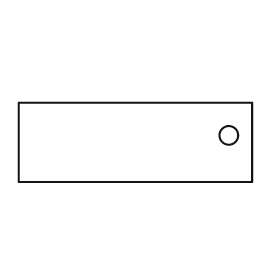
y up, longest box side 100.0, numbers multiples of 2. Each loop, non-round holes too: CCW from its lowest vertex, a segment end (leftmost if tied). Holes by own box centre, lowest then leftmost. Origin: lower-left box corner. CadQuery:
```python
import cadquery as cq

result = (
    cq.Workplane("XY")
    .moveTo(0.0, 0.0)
    .lineTo(100.0, 0.0)
    .lineTo(100.0, 34.0)
    .lineTo(0.0, 34.0)
    .close()
    .moveTo(90.0, 20.0)
    .circle(4.0)
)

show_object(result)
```